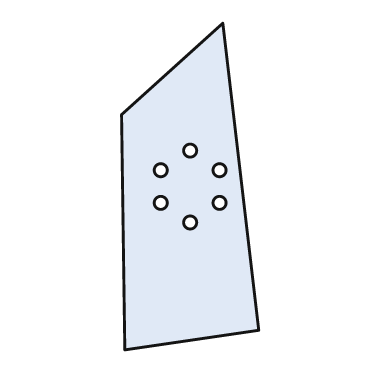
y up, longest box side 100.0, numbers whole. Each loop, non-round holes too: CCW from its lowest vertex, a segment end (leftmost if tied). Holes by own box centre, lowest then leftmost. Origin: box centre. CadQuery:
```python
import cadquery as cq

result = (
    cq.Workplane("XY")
    .moveTo(-20.0, -50.0)
    .lineTo(21.0, -44.0)
    .lineTo(10.0, 50.0)
    .lineTo(-21.0, 22.0)
    .close()
    .moveTo(0.0, -11.0)
    .circle(2.0)
    .moveTo(-9.0, -5.0)
    .circle(2.0)
    .moveTo(9.0, -5.0)
    .circle(2.0)
    .moveTo(-9.0, 5.0)
    .circle(2.0)
    .moveTo(9.0, 5.0)
    .circle(2.0)
    .moveTo(0.0, 11.0)
    .circle(2.0)
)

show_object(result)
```